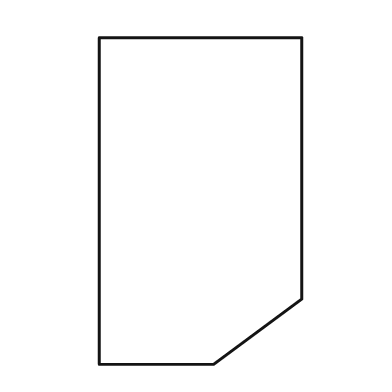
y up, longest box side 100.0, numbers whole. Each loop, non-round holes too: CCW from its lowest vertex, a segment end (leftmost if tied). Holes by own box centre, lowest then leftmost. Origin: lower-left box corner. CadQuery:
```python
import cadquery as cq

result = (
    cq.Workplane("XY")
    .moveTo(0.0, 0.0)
    .lineTo(35.0, 0.0)
    .lineTo(62.0, 20.0)
    .lineTo(62.0, 100.0)
    .lineTo(0.0, 100.0)
    .close()
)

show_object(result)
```